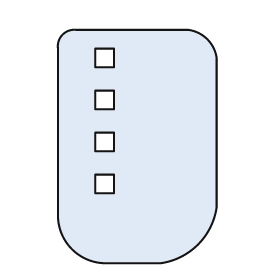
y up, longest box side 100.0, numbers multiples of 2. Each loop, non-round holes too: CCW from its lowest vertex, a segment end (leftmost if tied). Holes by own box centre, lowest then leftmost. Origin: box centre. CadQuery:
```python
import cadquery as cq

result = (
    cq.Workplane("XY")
    .moveTo(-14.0, -50.0)
    .lineTo(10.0, -50.0)
    .threePointArc((26.0, -42.0), (34.0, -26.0))
    .lineTo(34.0, 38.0)
    .threePointArc((30.0, 46.0), (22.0, 50.0))
    .lineTo(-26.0, 50.0)
    .threePointArc((-32.0, 48.0), (-34.0, 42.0))
    .lineTo(-34.0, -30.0)
    .threePointArc((-28.0, -44.0), (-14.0, -50.0))
    .close()
    .moveTo(-18.0, -20.0)
    .lineTo(-10.0, -20.0)
    .lineTo(-10.0, -12.0)
    .lineTo(-18.0, -12.0)
    .close()
    .moveTo(-18.0, -2.0)
    .lineTo(-10.0, -2.0)
    .lineTo(-10.0, 6.0)
    .lineTo(-18.0, 6.0)
    .close()
    .moveTo(-18.0, 16.0)
    .lineTo(-10.0, 16.0)
    .lineTo(-10.0, 24.0)
    .lineTo(-18.0, 24.0)
    .close()
    .moveTo(-18.0, 34.0)
    .lineTo(-10.0, 34.0)
    .lineTo(-10.0, 42.0)
    .lineTo(-18.0, 42.0)
    .close()
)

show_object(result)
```